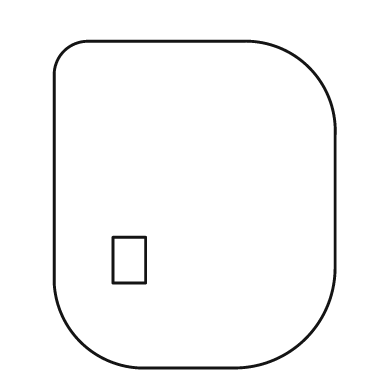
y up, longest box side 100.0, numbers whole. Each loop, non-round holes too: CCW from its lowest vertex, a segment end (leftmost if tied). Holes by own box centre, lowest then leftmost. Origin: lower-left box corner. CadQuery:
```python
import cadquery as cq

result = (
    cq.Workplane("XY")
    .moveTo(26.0, 0.0)
    .lineTo(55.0, 0.0)
    .threePointArc((77.0, 9.0), (86.0, 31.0))
    .lineTo(86.0, 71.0)
    .threePointArc((78.0, 92.0), (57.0, 100.0))
    .lineTo(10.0, 100.0)
    .threePointArc((3.0, 97.0), (0.0, 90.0))
    .lineTo(0.0, 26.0)
    .threePointArc((8.0, 8.0), (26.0, 0.0))
    .close()
    .moveTo(18.0, 26.0)
    .lineTo(28.0, 26.0)
    .lineTo(28.0, 40.0)
    .lineTo(18.0, 40.0)
    .close()
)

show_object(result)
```